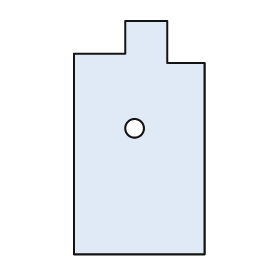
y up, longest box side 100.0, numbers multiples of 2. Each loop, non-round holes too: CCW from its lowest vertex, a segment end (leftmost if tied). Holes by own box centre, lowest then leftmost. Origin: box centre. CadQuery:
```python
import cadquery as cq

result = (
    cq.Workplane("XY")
    .moveTo(-28.0, -50.0)
    .lineTo(28.0, -50.0)
    .lineTo(28.0, 32.0)
    .lineTo(12.0, 32.0)
    .lineTo(12.0, 50.0)
    .lineTo(-6.0, 50.0)
    .lineTo(-6.0, 36.0)
    .lineTo(-28.0, 36.0)
    .close()
    .moveTo(-2.0, 4.0)
    .circle(4.0)
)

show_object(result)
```